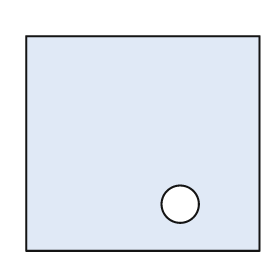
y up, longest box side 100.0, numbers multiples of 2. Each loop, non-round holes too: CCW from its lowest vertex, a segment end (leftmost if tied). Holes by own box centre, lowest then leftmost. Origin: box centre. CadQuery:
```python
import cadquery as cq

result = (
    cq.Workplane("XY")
    .moveTo(-50.0, -46.0)
    .lineTo(50.0, -46.0)
    .lineTo(50.0, 46.0)
    .lineTo(-50.0, 46.0)
    .close()
    .moveTo(16.0, -26.0)
    .circle(8.0)
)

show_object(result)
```